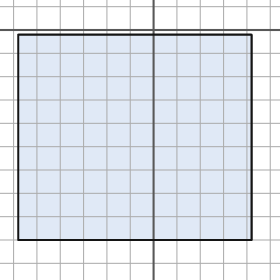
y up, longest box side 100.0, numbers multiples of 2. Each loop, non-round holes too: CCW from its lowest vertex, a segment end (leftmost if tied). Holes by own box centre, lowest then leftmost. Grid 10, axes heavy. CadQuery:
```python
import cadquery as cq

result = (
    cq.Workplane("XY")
    .moveTo(-58.0, -90.0)
    .lineTo(42.0, -90.0)
    .lineTo(42.0, -2.0)
    .lineTo(-58.0, -2.0)
    .close()
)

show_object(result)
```